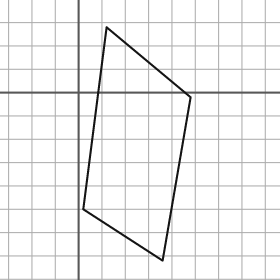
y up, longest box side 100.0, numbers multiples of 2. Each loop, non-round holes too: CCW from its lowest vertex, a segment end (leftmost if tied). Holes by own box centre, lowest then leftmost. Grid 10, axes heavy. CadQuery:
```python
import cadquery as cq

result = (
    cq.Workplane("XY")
    .moveTo(36.0, -72.0)
    .lineTo(48.0, -2.0)
    .lineTo(12.0, 28.0)
    .lineTo(2.0, -50.0)
    .close()
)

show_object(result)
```